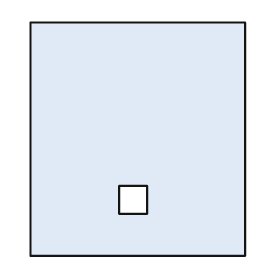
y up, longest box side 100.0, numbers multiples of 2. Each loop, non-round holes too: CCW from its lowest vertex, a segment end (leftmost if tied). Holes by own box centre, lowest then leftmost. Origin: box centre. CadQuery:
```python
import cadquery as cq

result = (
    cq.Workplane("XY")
    .moveTo(-46.0, -50.0)
    .lineTo(46.0, -50.0)
    .lineTo(46.0, 50.0)
    .lineTo(-46.0, 50.0)
    .close()
    .moveTo(-8.0, -32.0)
    .lineTo(4.0, -32.0)
    .lineTo(4.0, -20.0)
    .lineTo(-8.0, -20.0)
    .close()
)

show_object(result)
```